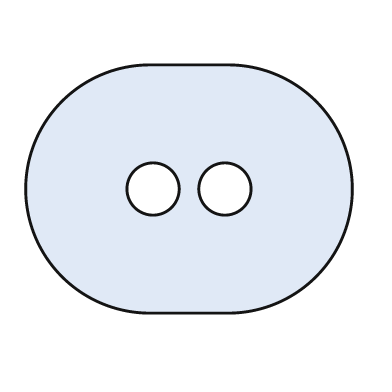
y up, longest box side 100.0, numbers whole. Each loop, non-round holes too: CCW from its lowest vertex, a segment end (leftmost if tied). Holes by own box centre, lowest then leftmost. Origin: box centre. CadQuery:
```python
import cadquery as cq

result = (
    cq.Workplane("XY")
    .moveTo(-12.0, -38.0)
    .lineTo(12.0, -38.0)
    .threePointArc((50.0, 0.0), (12.0, 38.0))
    .lineTo(-12.0, 38.0)
    .threePointArc((-50.0, 0.0), (-12.0, -38.0))
    .close()
    .moveTo(-11.0, 0.0)
    .circle(8.0)
    .moveTo(11.0, 0.0)
    .circle(8.0)
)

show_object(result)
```